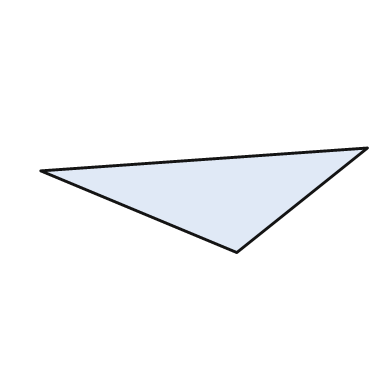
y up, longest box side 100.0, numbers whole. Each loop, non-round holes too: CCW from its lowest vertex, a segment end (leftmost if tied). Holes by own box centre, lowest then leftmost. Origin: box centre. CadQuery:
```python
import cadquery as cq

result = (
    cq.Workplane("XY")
    .moveTo(10.0, -16.0)
    .lineTo(50.0, 16.0)
    .lineTo(-50.0, 9.0)
    .close()
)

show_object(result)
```